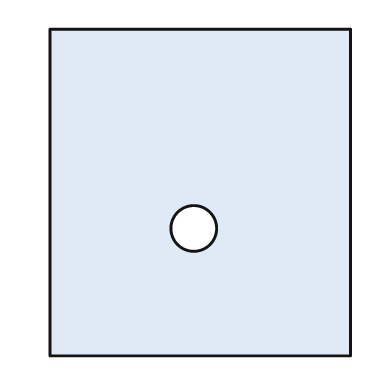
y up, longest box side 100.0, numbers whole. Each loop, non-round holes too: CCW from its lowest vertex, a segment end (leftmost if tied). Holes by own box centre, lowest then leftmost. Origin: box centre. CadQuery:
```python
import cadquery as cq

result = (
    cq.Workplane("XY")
    .moveTo(-46.0, -50.0)
    .lineTo(46.0, -50.0)
    .lineTo(46.0, 50.0)
    .lineTo(-46.0, 50.0)
    .close()
    .moveTo(-2.0, -11.0)
    .circle(7.0)
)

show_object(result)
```